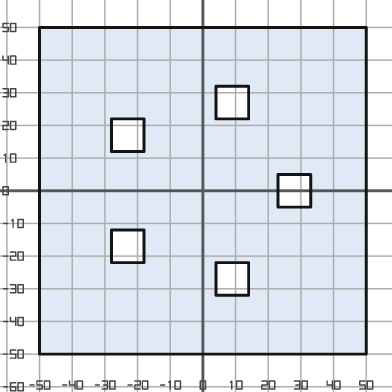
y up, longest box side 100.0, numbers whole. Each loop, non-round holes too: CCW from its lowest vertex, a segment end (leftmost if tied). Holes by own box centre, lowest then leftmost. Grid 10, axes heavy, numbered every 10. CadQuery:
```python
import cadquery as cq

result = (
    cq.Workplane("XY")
    .moveTo(-50.0, -50.0)
    .lineTo(50.0, -50.0)
    .lineTo(50.0, 50.0)
    .lineTo(-50.0, 50.0)
    .close()
    .moveTo(4.0, -32.0)
    .lineTo(14.0, -32.0)
    .lineTo(14.0, -22.0)
    .lineTo(4.0, -22.0)
    .close()
    .moveTo(-28.0, -22.0)
    .lineTo(-18.0, -22.0)
    .lineTo(-18.0, -12.0)
    .lineTo(-28.0, -12.0)
    .close()
    .moveTo(23.0, -5.0)
    .lineTo(33.0, -5.0)
    .lineTo(33.0, 5.0)
    .lineTo(23.0, 5.0)
    .close()
    .moveTo(-28.0, 12.0)
    .lineTo(-18.0, 12.0)
    .lineTo(-18.0, 22.0)
    .lineTo(-28.0, 22.0)
    .close()
    .moveTo(4.0, 22.0)
    .lineTo(14.0, 22.0)
    .lineTo(14.0, 32.0)
    .lineTo(4.0, 32.0)
    .close()
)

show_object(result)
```